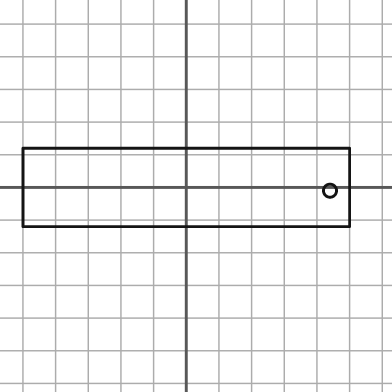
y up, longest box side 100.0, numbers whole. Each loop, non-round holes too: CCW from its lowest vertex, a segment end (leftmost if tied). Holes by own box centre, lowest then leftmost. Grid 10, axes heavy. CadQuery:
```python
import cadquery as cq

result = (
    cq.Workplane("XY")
    .moveTo(-50.0, -12.0)
    .lineTo(50.0, -12.0)
    .lineTo(50.0, 12.0)
    .lineTo(-50.0, 12.0)
    .close()
    .moveTo(44.0, -1.0)
    .circle(2.0)
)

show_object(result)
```